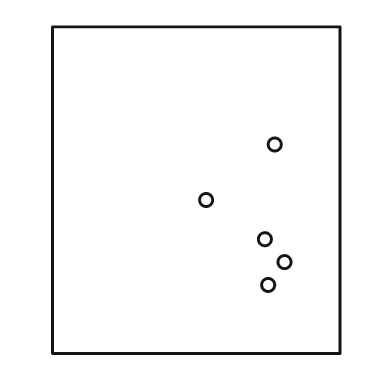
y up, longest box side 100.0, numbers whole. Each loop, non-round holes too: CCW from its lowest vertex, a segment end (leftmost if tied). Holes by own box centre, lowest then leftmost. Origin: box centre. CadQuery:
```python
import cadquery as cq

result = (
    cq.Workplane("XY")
    .moveTo(-44.0, -50.0)
    .lineTo(44.0, -50.0)
    .lineTo(44.0, 50.0)
    .lineTo(-44.0, 50.0)
    .close()
    .moveTo(22.0, -29.0)
    .circle(2.0)
    .moveTo(27.0, -22.0)
    .circle(2.0)
    .moveTo(21.0, -15.0)
    .circle(2.0)
    .moveTo(3.0, -3.0)
    .circle(2.0)
    .moveTo(24.0, 14.0)
    .circle(2.0)
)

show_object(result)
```